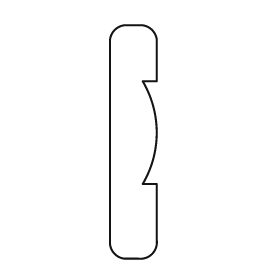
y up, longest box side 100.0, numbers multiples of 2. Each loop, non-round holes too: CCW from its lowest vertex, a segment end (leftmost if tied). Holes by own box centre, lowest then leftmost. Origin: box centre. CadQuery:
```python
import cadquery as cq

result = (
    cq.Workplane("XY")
    .moveTo(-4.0, -50.0)
    .lineTo(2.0, -50.0)
    .threePointArc((8.0, -48.0), (10.0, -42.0))
    .lineTo(10.0, -18.0)
    .lineTo(4.0, -18.0)
    .threePointArc((10.0, 4.0), (4.0, 26.0))
    .lineTo(10.0, 26.0)
    .lineTo(10.0, 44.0)
    .threePointArc((8.0, 48.0), (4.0, 50.0))
    .lineTo(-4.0, 50.0)
    .threePointArc((-8.0, 48.0), (-10.0, 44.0))
    .lineTo(-10.0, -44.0)
    .threePointArc((-8.0, -48.0), (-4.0, -50.0))
    .close()
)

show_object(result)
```